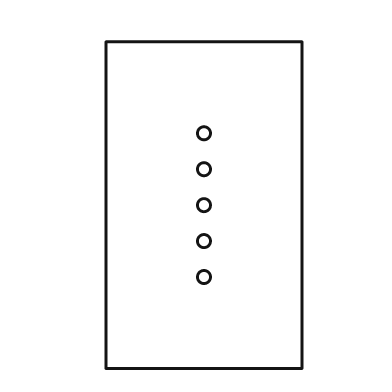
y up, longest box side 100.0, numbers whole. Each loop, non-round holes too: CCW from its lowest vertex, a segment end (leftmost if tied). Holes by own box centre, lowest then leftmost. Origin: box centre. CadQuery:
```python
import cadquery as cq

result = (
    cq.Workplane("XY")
    .moveTo(-30.0, -50.0)
    .lineTo(30.0, -50.0)
    .lineTo(30.0, 50.0)
    .lineTo(-30.0, 50.0)
    .close()
    .moveTo(0.0, -22.0)
    .circle(2.0)
    .moveTo(0.0, -11.0)
    .circle(2.0)
    .moveTo(0.0, 0.0)
    .circle(2.0)
    .moveTo(0.0, 11.0)
    .circle(2.0)
    .moveTo(0.0, 22.0)
    .circle(2.0)
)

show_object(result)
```